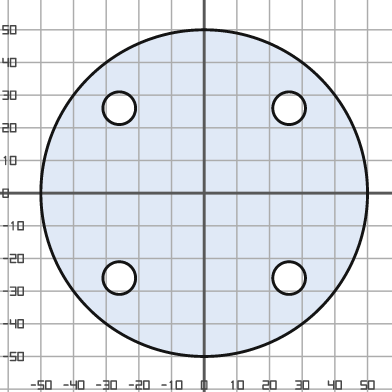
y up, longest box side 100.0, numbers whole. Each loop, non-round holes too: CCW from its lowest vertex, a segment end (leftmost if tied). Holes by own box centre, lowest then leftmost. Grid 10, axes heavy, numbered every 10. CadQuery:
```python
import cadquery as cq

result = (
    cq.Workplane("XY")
    .moveTo(0.0, 0.0)
    .circle(50.0)
    .moveTo(-26.0, -26.0)
    .circle(5.0)
    .moveTo(26.0, -26.0)
    .circle(5.0)
    .moveTo(-26.0, 26.0)
    .circle(5.0)
    .moveTo(26.0, 26.0)
    .circle(5.0)
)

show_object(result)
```